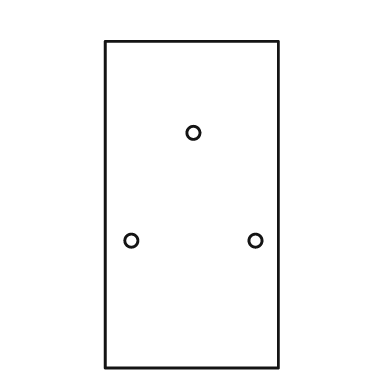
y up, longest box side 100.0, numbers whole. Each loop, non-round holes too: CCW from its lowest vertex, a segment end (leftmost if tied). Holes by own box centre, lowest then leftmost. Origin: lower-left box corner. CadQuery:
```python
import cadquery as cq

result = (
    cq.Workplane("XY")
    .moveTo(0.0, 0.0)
    .lineTo(53.0, 0.0)
    .lineTo(53.0, 100.0)
    .lineTo(0.0, 100.0)
    .close()
    .moveTo(8.0, 39.0)
    .circle(2.0)
    .moveTo(46.0, 39.0)
    .circle(2.0)
    .moveTo(27.0, 72.0)
    .circle(2.0)
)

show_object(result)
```